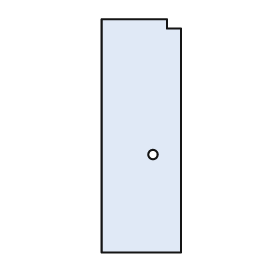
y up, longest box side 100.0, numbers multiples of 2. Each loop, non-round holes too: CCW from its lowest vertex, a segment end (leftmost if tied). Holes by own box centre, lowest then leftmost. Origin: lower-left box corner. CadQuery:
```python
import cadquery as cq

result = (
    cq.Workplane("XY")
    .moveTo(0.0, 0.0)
    .lineTo(34.0, 0.0)
    .lineTo(34.0, 96.0)
    .lineTo(28.0, 96.0)
    .lineTo(28.0, 100.0)
    .lineTo(0.0, 100.0)
    .close()
    .moveTo(22.0, 42.0)
    .circle(2.0)
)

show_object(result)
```